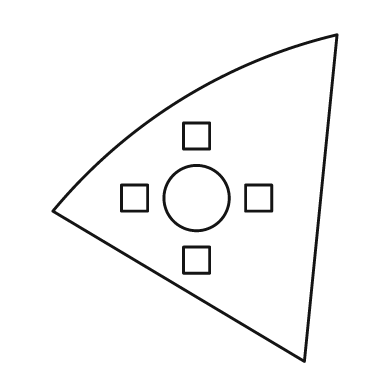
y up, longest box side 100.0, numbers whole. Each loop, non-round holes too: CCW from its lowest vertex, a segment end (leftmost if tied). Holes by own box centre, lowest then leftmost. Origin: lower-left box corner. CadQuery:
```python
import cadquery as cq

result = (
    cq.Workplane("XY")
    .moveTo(77.0, 0.0)
    .lineTo(87.0, 100.0)
    .threePointArc((39.0, 80.0), (0.0, 46.0))
    .close()
    .moveTo(40.0, 27.0)
    .lineTo(48.0, 27.0)
    .lineTo(48.0, 35.0)
    .lineTo(40.0, 35.0)
    .close()
    .moveTo(21.0, 46.0)
    .lineTo(29.0, 46.0)
    .lineTo(29.0, 54.0)
    .lineTo(21.0, 54.0)
    .close()
    .moveTo(44.0, 50.0)
    .circle(10.0)
    .moveTo(59.0, 46.0)
    .lineTo(67.0, 46.0)
    .lineTo(67.0, 54.0)
    .lineTo(59.0, 54.0)
    .close()
    .moveTo(40.0, 65.0)
    .lineTo(48.0, 65.0)
    .lineTo(48.0, 73.0)
    .lineTo(40.0, 73.0)
    .close()
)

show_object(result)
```